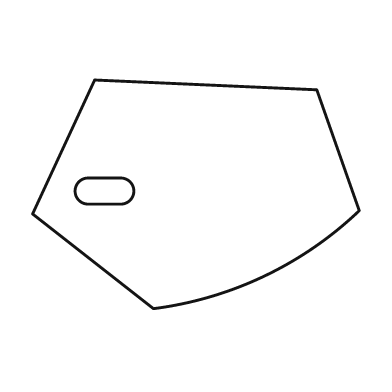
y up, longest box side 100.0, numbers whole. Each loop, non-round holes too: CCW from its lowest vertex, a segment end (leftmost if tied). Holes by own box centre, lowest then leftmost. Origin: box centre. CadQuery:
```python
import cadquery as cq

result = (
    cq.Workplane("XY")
    .moveTo(-13.0, -35.0)
    .threePointArc((21.0, -25.0), (50.0, -5.0))
    .lineTo(37.0, 32.0)
    .lineTo(-31.0, 35.0)
    .lineTo(-50.0, -6.0)
    .close()
    .moveTo(-33.0, -3.0)
    .lineTo(-23.0, -3.0)
    .threePointArc((-19.0, 1.0), (-23.0, 5.0))
    .lineTo(-33.0, 5.0)
    .threePointArc((-37.0, 1.0), (-33.0, -3.0))
    .close()
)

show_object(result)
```